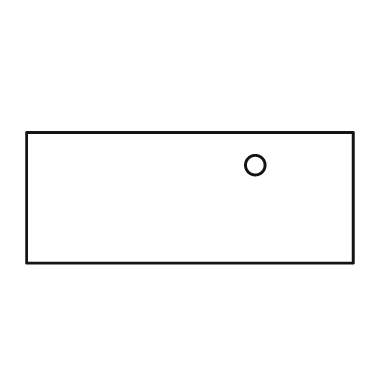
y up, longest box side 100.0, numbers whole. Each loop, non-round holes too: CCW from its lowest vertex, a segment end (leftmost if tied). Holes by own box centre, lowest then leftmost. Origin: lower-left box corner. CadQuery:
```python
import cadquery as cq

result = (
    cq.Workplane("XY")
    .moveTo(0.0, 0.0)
    .lineTo(100.0, 0.0)
    .lineTo(100.0, 40.0)
    .lineTo(0.0, 40.0)
    .close()
    .moveTo(70.0, 30.0)
    .circle(3.0)
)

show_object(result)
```